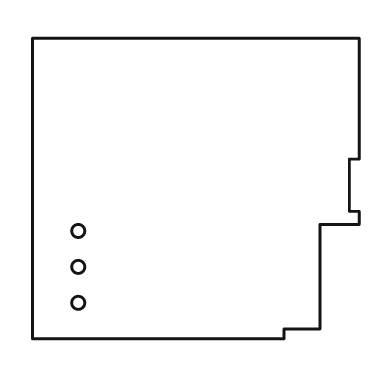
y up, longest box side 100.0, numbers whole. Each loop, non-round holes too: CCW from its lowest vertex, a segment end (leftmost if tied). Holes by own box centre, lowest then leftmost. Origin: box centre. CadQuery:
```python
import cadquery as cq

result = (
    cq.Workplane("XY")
    .moveTo(-50.0, -46.0)
    .lineTo(27.0, -46.0)
    .lineTo(27.0, -43.0)
    .lineTo(38.0, -43.0)
    .lineTo(38.0, -11.0)
    .lineTo(50.0, -11.0)
    .lineTo(50.0, -7.0)
    .lineTo(47.0, -7.0)
    .lineTo(47.0, 9.0)
    .lineTo(50.0, 9.0)
    .lineTo(50.0, 46.0)
    .lineTo(-50.0, 46.0)
    .close()
    .moveTo(-36.0, -35.0)
    .circle(2.0)
    .moveTo(-36.0, -24.0)
    .circle(2.0)
    .moveTo(-36.0, -13.0)
    .circle(2.0)
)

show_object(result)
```